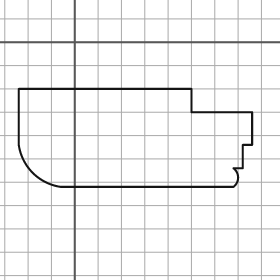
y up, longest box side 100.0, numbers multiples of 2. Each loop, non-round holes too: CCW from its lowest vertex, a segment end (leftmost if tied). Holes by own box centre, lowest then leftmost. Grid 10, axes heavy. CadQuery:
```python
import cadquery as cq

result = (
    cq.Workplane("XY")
    .moveTo(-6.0, -62.0)
    .lineTo(68.0, -62.0)
    .threePointArc((70.0, -58.0), (68.0, -54.0))
    .lineTo(72.0, -54.0)
    .lineTo(72.0, -44.0)
    .lineTo(76.0, -44.0)
    .lineTo(76.0, -30.0)
    .lineTo(50.0, -30.0)
    .lineTo(50.0, -20.0)
    .lineTo(-24.0, -20.0)
    .lineTo(-24.0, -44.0)
    .threePointArc((-18.0, -56.0), (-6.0, -62.0))
    .close()
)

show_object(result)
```